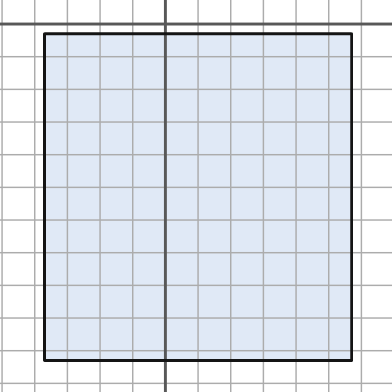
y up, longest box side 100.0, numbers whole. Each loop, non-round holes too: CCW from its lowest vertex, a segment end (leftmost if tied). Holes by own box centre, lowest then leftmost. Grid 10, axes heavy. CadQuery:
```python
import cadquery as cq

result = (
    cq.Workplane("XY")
    .moveTo(-37.0, -103.0)
    .lineTo(57.0, -103.0)
    .lineTo(57.0, -3.0)
    .lineTo(-37.0, -3.0)
    .close()
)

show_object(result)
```